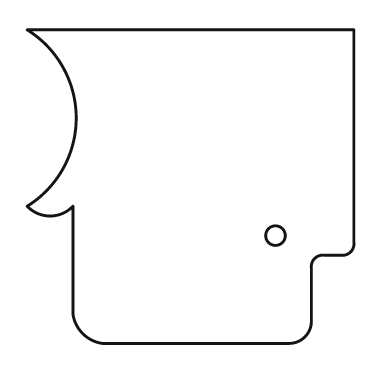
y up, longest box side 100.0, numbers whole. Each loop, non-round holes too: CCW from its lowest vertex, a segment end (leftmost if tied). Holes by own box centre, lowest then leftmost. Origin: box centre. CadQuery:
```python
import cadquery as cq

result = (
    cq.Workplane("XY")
    .moveTo(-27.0, -48.0)
    .lineTo(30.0, -48.0)
    .threePointArc((35.0, -46.0), (37.0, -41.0))
    .lineTo(37.0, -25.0)
    .threePointArc((38.0, -22.0), (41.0, -21.0))
    .lineTo(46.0, -21.0)
    .threePointArc((49.0, -20.0), (50.0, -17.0))
    .lineTo(50.0, 48.0)
    .lineTo(-50.0, 48.0)
    .threePointArc((-35.0, 21.0), (-50.0, -6.0))
    .threePointArc((-43.0, -9.0), (-36.0, -6.0))
    .lineTo(-36.0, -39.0)
    .threePointArc((-33.0, -45.0), (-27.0, -48.0))
    .close()
    .moveTo(26.0, -15.0)
    .circle(3.0)
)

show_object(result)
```